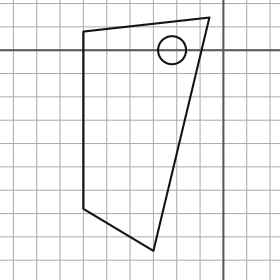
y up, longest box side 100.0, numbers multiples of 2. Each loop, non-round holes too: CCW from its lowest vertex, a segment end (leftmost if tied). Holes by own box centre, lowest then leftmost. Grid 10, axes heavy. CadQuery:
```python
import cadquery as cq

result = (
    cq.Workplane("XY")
    .moveTo(-30.0, -86.0)
    .lineTo(-6.0, 14.0)
    .lineTo(-60.0, 8.0)
    .lineTo(-60.0, -68.0)
    .close()
    .moveTo(-22.0, 0.0)
    .circle(6.0)
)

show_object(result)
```